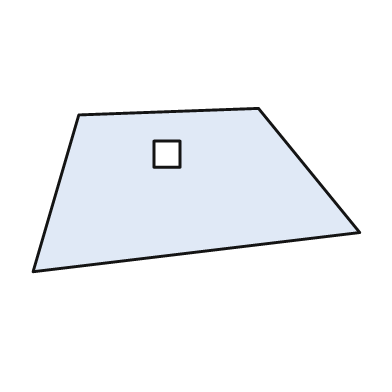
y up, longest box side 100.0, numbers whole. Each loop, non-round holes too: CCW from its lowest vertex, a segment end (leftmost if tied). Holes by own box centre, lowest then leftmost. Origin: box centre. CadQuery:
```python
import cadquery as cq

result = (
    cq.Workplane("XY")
    .moveTo(-50.0, -25.0)
    .lineTo(50.0, -13.0)
    .lineTo(19.0, 25.0)
    .lineTo(-36.0, 23.0)
    .close()
    .moveTo(-13.0, 7.0)
    .lineTo(-5.0, 7.0)
    .lineTo(-5.0, 15.0)
    .lineTo(-13.0, 15.0)
    .close()
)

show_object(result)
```